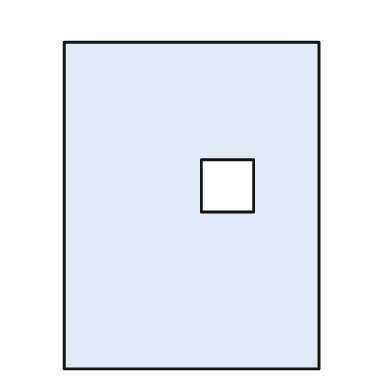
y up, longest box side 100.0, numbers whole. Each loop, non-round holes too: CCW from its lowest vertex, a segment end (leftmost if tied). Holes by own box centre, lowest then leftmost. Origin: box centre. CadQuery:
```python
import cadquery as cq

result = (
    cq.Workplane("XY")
    .moveTo(-39.0, -50.0)
    .lineTo(39.0, -50.0)
    .lineTo(39.0, 50.0)
    .lineTo(-39.0, 50.0)
    .close()
    .moveTo(3.0, -2.0)
    .lineTo(19.0, -2.0)
    .lineTo(19.0, 14.0)
    .lineTo(3.0, 14.0)
    .close()
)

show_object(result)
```